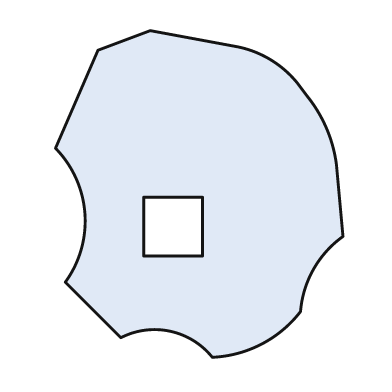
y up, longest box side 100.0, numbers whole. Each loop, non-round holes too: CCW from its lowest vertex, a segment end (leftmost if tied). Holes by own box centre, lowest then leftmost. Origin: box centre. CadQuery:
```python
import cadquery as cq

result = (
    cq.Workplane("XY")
    .moveTo(4.0, -50.0)
    .threePointArc((19.0, -46.0), (31.0, -36.0))
    .threePointArc((35.0, -23.0), (44.0, -13.0))
    .lineTo(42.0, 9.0)
    .threePointArc((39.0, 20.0), (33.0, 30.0))
    .lineTo(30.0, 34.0)
    .threePointArc((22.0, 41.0), (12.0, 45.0))
    .lineTo(-15.0, 50.0)
    .lineTo(-31.0, 44.0)
    .lineTo(-44.0, 14.0)
    .threePointArc((-35.0, -6.0), (-41.0, -27.0))
    .lineTo(-24.0, -44.0)
    .threePointArc((-9.0, -42.0), (4.0, -50.0))
    .close()
    .moveTo(-17.0, -19.0)
    .lineTo(1.0, -19.0)
    .lineTo(1.0, -1.0)
    .lineTo(-17.0, -1.0)
    .close()
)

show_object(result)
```